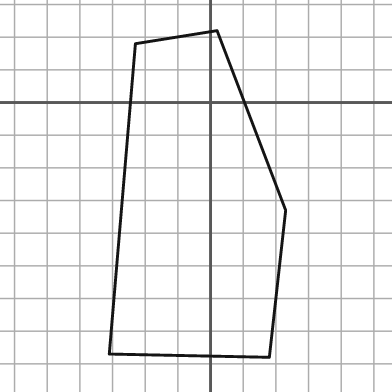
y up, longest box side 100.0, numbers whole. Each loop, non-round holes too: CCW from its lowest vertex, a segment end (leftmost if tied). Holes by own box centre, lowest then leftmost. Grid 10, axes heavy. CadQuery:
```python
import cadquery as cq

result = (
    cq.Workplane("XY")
    .moveTo(18.0, -78.0)
    .lineTo(23.0, -33.0)
    .lineTo(2.0, 22.0)
    .lineTo(-23.0, 18.0)
    .lineTo(-31.0, -77.0)
    .close()
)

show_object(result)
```